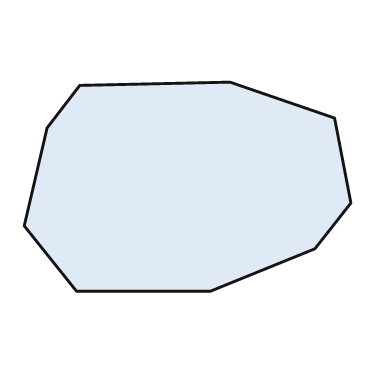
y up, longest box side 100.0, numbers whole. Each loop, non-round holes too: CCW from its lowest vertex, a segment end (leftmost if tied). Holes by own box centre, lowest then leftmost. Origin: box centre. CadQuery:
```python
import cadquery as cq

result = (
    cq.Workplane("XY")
    .moveTo(-34.0, -32.0)
    .lineTo(7.0, -32.0)
    .lineTo(39.0, -19.0)
    .lineTo(50.0, -5.0)
    .lineTo(45.0, 21.0)
    .lineTo(13.0, 32.0)
    .lineTo(-33.0, 31.0)
    .lineTo(-43.0, 18.0)
    .lineTo(-50.0, -12.0)
    .close()
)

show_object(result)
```